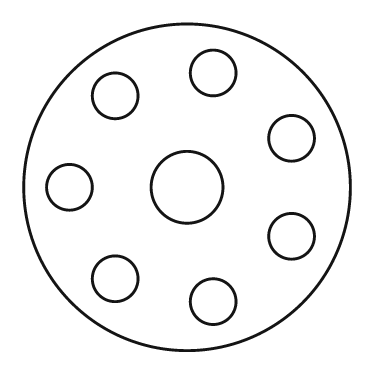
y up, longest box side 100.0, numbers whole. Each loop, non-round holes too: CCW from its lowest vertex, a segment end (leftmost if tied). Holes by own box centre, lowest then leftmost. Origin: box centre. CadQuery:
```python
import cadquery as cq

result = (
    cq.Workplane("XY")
    .moveTo(0.0, 0.0)
    .circle(50.0)
    .moveTo(8.0, -35.0)
    .circle(7.0)
    .moveTo(-22.0, -28.0)
    .circle(7.0)
    .moveTo(32.0, -15.0)
    .circle(7.0)
    .moveTo(-36.0, 0.0)
    .circle(7.0)
    .moveTo(0.0, 0.0)
    .circle(11.0)
    .moveTo(32.0, 15.0)
    .circle(7.0)
    .moveTo(-22.0, 28.0)
    .circle(7.0)
    .moveTo(8.0, 35.0)
    .circle(7.0)
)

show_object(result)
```